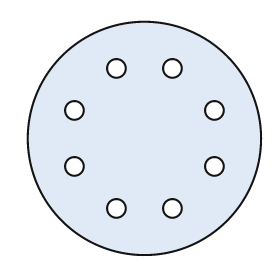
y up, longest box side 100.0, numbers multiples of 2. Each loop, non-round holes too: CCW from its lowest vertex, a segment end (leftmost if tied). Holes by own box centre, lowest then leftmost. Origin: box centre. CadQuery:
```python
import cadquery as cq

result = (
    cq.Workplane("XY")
    .moveTo(0.0, 0.0)
    .circle(50.0)
    .moveTo(-12.0, -30.0)
    .circle(4.0)
    .moveTo(12.0, -30.0)
    .circle(4.0)
    .moveTo(-30.0, -12.0)
    .circle(4.0)
    .moveTo(30.0, -12.0)
    .circle(4.0)
    .moveTo(-30.0, 12.0)
    .circle(4.0)
    .moveTo(30.0, 12.0)
    .circle(4.0)
    .moveTo(-12.0, 30.0)
    .circle(4.0)
    .moveTo(12.0, 30.0)
    .circle(4.0)
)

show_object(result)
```